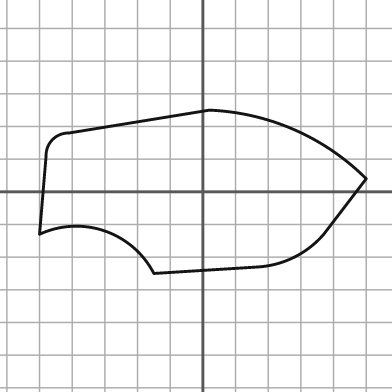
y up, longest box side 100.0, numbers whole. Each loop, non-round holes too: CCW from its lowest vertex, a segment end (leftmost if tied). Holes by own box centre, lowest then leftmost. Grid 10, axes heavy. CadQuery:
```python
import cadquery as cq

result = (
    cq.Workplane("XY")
    .moveTo(-15.0, -25.0)
    .lineTo(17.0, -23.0)
    .threePointArc((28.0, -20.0), (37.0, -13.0))
    .lineTo(50.0, 4.0)
    .threePointArc((28.0, 19.0), (2.0, 25.0))
    .lineTo(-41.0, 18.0)
    .threePointArc((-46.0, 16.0), (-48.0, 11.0))
    .lineTo(-50.0, -13.0)
    .threePointArc((-30.0, -12.0), (-15.0, -25.0))
    .close()
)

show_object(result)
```